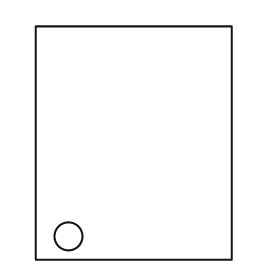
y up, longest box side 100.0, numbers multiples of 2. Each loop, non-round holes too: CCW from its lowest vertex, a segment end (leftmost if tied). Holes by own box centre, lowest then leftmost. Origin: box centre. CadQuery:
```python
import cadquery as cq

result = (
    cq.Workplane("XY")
    .moveTo(-42.0, -50.0)
    .lineTo(42.0, -50.0)
    .lineTo(42.0, 50.0)
    .lineTo(-42.0, 50.0)
    .close()
    .moveTo(-28.0, -40.0)
    .circle(6.0)
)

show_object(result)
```